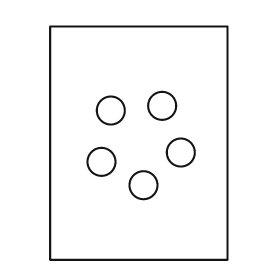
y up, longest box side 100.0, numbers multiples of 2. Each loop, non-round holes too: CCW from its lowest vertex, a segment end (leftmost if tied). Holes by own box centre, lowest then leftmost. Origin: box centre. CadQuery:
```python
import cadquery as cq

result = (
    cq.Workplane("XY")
    .moveTo(-38.0, -50.0)
    .lineTo(38.0, -50.0)
    .lineTo(38.0, 50.0)
    .lineTo(-38.0, 50.0)
    .close()
    .moveTo(2.0, -18.0)
    .circle(6.0)
    .moveTo(-16.0, -8.0)
    .circle(6.0)
    .moveTo(18.0, -4.0)
    .circle(6.0)
    .moveTo(-12.0, 14.0)
    .circle(6.0)
    .moveTo(10.0, 16.0)
    .circle(6.0)
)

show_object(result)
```